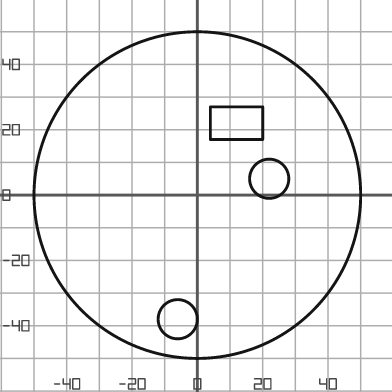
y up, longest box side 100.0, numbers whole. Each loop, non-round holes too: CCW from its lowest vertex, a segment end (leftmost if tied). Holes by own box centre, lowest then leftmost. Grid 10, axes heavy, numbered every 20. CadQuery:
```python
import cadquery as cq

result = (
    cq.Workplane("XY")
    .moveTo(0.0, 0.0)
    .circle(50.0)
    .moveTo(-6.0, -38.0)
    .circle(6.0)
    .moveTo(22.0, 5.0)
    .circle(6.0)
    .moveTo(4.0, 17.0)
    .lineTo(20.0, 17.0)
    .lineTo(20.0, 27.0)
    .lineTo(4.0, 27.0)
    .close()
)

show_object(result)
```